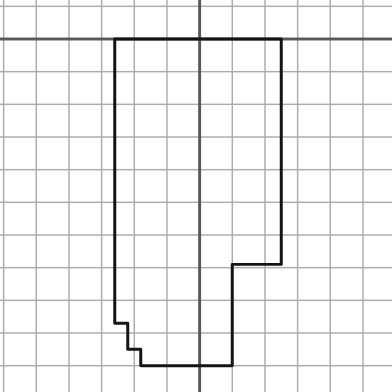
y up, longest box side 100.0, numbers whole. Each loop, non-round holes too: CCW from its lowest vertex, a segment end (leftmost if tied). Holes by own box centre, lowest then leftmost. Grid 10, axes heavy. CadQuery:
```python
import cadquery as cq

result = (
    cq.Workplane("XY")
    .moveTo(-18.0, -100.0)
    .lineTo(10.0, -100.0)
    .lineTo(10.0, -69.0)
    .lineTo(25.0, -69.0)
    .lineTo(25.0, 0.0)
    .lineTo(-26.0, 0.0)
    .lineTo(-26.0, -87.0)
    .lineTo(-22.0, -87.0)
    .lineTo(-22.0, -95.0)
    .lineTo(-18.0, -95.0)
    .close()
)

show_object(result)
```